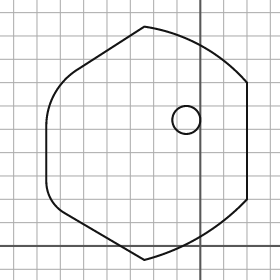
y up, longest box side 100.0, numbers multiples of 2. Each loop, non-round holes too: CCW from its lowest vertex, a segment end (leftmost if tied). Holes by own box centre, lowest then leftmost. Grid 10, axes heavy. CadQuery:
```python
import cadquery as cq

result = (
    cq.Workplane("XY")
    .moveTo(-24.0, -6.0)
    .threePointArc((0.0, 4.0), (20.0, 20.0))
    .lineTo(20.0, 70.0)
    .threePointArc((0.0, 86.0), (-24.0, 94.0))
    .lineTo(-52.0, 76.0)
    .threePointArc((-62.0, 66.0), (-66.0, 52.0))
    .lineTo(-66.0, 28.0)
    .threePointArc((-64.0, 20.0), (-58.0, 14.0))
    .close()
    .moveTo(-6.0, 54.0)
    .circle(6.0)
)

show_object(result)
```